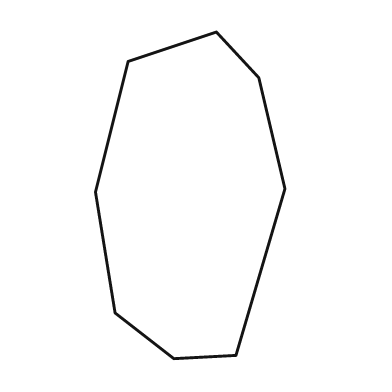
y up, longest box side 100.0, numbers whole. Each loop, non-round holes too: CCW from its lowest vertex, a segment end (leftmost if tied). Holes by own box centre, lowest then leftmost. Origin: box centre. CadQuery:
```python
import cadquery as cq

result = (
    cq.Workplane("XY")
    .moveTo(-5.0, -50.0)
    .lineTo(14.0, -49.0)
    .lineTo(29.0, 2.0)
    .lineTo(21.0, 36.0)
    .lineTo(8.0, 50.0)
    .lineTo(-19.0, 41.0)
    .lineTo(-29.0, 1.0)
    .lineTo(-23.0, -36.0)
    .close()
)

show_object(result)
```